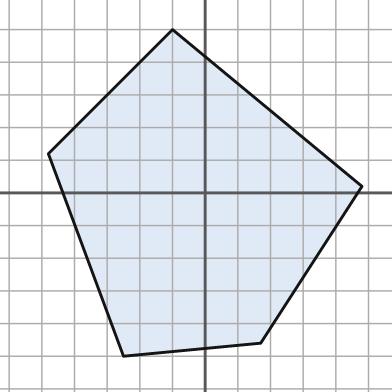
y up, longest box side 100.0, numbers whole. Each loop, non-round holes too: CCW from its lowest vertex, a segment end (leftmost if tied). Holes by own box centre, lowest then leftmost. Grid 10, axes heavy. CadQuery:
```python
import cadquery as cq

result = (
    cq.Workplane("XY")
    .moveTo(-25.0, -50.0)
    .lineTo(17.0, -46.0)
    .lineTo(48.0, 2.0)
    .lineTo(-10.0, 50.0)
    .lineTo(-48.0, 12.0)
    .close()
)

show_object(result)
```